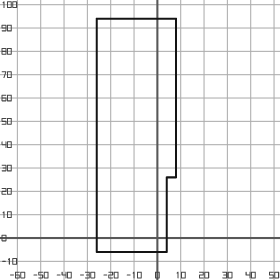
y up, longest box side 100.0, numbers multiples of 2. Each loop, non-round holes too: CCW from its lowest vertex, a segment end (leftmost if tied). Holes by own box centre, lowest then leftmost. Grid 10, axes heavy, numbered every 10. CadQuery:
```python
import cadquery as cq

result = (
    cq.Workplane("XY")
    .moveTo(-26.0, -6.0)
    .lineTo(4.0, -6.0)
    .lineTo(4.0, 26.0)
    .lineTo(8.0, 26.0)
    .lineTo(8.0, 94.0)
    .lineTo(-26.0, 94.0)
    .close()
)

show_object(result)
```